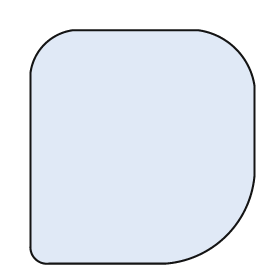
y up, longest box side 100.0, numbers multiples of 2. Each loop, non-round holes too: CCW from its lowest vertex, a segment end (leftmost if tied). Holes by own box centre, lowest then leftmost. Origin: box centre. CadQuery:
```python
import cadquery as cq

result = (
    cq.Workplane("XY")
    .moveTo(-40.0, -50.0)
    .lineTo(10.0, -50.0)
    .threePointArc((36.0, -38.0), (48.0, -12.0))
    .lineTo(48.0, 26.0)
    .threePointArc((40.0, 42.0), (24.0, 50.0))
    .lineTo(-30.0, 50.0)
    .threePointArc((-42.0, 44.0), (-48.0, 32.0))
    .lineTo(-48.0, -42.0)
    .threePointArc((-46.0, -48.0), (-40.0, -50.0))
    .close()
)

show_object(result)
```